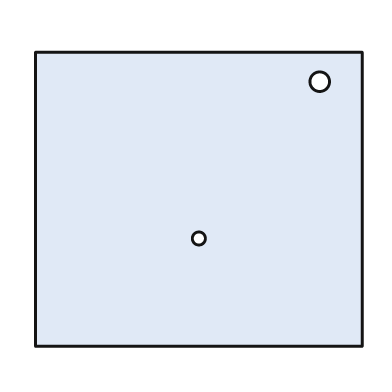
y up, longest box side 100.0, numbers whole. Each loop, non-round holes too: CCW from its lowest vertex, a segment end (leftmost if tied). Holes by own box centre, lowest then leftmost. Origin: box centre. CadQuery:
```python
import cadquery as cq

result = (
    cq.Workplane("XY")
    .moveTo(-50.0, -45.0)
    .lineTo(50.0, -45.0)
    .lineTo(50.0, 45.0)
    .lineTo(-50.0, 45.0)
    .close()
    .moveTo(0.0, -12.0)
    .circle(2.0)
    .moveTo(37.0, 36.0)
    .circle(3.0)
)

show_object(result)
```